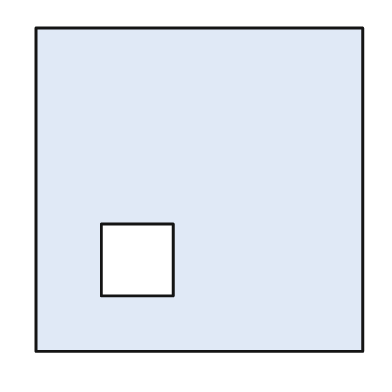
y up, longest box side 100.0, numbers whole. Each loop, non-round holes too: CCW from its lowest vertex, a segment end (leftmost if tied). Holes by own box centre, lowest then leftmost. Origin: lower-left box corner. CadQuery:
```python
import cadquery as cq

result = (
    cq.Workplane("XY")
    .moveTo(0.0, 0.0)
    .lineTo(100.0, 0.0)
    .lineTo(100.0, 99.0)
    .lineTo(0.0, 99.0)
    .close()
    .moveTo(20.0, 17.0)
    .lineTo(42.0, 17.0)
    .lineTo(42.0, 39.0)
    .lineTo(20.0, 39.0)
    .close()
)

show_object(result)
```